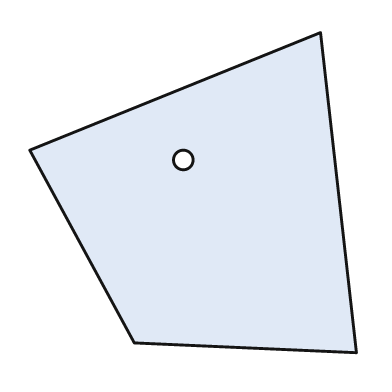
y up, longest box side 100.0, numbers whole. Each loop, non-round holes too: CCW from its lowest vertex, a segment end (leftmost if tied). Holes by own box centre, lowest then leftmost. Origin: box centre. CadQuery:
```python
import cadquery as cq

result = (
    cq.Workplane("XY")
    .moveTo(50.0, -49.0)
    .lineTo(39.0, 49.0)
    .lineTo(-50.0, 13.0)
    .lineTo(-18.0, -46.0)
    .close()
    .moveTo(-3.0, 10.0)
    .circle(3.0)
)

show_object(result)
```